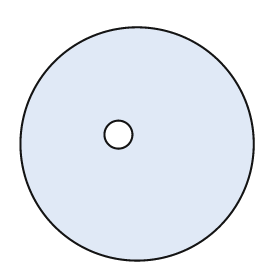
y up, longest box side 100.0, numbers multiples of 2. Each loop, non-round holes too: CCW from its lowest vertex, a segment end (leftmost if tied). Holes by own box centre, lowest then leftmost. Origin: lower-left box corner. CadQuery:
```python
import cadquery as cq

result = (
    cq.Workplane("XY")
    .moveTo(50.0, 50.0)
    .circle(50.0)
    .moveTo(42.0, 54.0)
    .circle(6.0)
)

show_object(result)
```